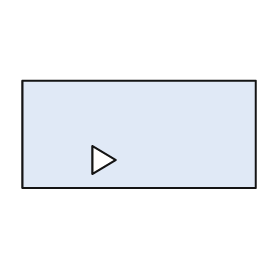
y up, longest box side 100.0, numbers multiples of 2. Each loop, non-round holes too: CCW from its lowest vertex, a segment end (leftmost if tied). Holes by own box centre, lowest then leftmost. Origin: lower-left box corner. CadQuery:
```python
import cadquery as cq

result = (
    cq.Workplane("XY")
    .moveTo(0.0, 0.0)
    .lineTo(100.0, 0.0)
    .lineTo(100.0, 46.0)
    .lineTo(0.0, 46.0)
    .close()
    .moveTo(30.0, 6.0)
    .lineTo(40.0, 12.0)
    .lineTo(30.0, 18.0)
    .close()
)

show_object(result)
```